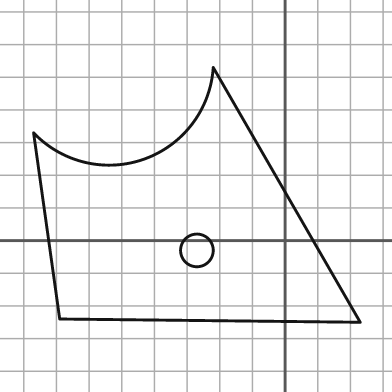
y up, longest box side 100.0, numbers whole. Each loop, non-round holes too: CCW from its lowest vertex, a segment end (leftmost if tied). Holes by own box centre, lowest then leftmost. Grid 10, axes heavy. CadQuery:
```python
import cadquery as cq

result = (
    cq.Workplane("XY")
    .moveTo(23.0, -25.0)
    .lineTo(-22.0, 53.0)
    .threePointArc((-43.0, 25.0), (-77.0, 33.0))
    .lineTo(-69.0, -24.0)
    .close()
    .moveTo(-27.0, -3.0)
    .circle(5.0)
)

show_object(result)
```